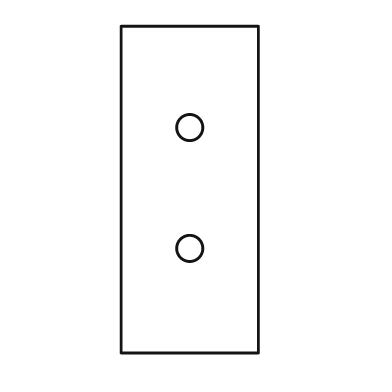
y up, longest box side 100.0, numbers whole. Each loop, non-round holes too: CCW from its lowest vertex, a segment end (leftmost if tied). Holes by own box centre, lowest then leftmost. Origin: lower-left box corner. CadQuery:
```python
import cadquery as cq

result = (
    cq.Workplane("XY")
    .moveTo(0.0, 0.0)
    .lineTo(42.0, 0.0)
    .lineTo(42.0, 100.0)
    .lineTo(0.0, 100.0)
    .close()
    .moveTo(21.0, 32.0)
    .circle(4.0)
    .moveTo(21.0, 69.0)
    .circle(4.0)
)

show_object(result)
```